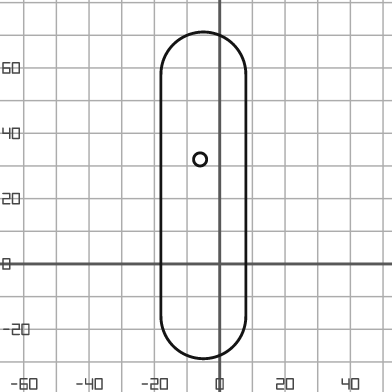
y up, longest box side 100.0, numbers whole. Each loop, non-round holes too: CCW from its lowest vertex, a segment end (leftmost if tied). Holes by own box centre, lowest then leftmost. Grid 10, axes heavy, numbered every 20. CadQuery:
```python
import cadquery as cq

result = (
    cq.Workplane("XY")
    .moveTo(-18.0, -16.0)
    .threePointArc((-5.0, -29.0), (8.0, -16.0))
    .lineTo(8.0, 58.0)
    .threePointArc((-5.0, 71.0), (-18.0, 58.0))
    .close()
    .moveTo(-6.0, 32.0)
    .circle(2.0)
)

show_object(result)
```